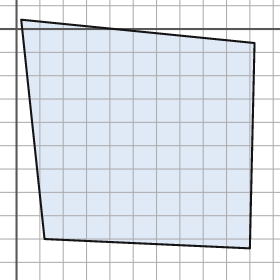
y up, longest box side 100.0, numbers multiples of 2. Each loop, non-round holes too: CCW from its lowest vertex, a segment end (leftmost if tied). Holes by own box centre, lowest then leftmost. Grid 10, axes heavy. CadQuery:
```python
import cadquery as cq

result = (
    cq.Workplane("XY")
    .moveTo(100.0, -94.0)
    .lineTo(102.0, -6.0)
    .lineTo(2.0, 4.0)
    .lineTo(12.0, -90.0)
    .close()
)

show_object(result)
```